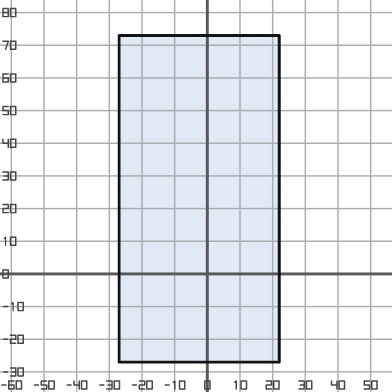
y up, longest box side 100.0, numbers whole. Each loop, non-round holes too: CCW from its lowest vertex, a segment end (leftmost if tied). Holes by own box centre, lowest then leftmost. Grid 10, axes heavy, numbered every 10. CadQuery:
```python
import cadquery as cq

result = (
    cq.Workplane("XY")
    .moveTo(-27.0, -27.0)
    .lineTo(22.0, -27.0)
    .lineTo(22.0, 73.0)
    .lineTo(-27.0, 73.0)
    .close()
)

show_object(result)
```